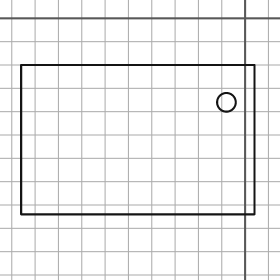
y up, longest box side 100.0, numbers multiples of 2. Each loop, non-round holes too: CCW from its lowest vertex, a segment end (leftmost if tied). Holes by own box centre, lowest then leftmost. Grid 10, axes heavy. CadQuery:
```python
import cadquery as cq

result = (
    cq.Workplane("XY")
    .moveTo(-96.0, -84.0)
    .lineTo(4.0, -84.0)
    .lineTo(4.0, -20.0)
    .lineTo(-96.0, -20.0)
    .close()
    .moveTo(-8.0, -36.0)
    .circle(4.0)
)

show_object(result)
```